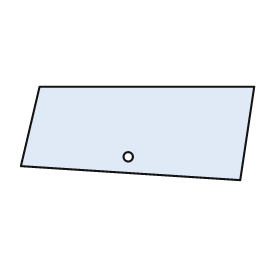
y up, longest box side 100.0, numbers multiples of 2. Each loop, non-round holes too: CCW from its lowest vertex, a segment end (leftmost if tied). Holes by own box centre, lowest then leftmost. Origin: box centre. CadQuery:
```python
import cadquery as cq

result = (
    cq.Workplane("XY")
    .moveTo(44.0, -20.0)
    .lineTo(50.0, 20.0)
    .lineTo(-42.0, 20.0)
    .lineTo(-50.0, -14.0)
    .close()
    .moveTo(-4.0, -10.0)
    .circle(2.0)
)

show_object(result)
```